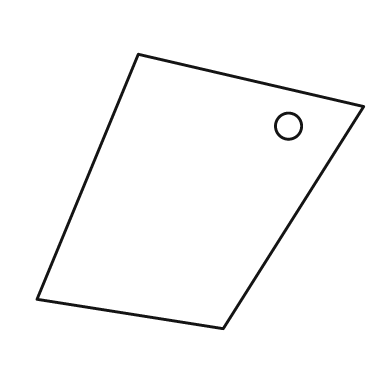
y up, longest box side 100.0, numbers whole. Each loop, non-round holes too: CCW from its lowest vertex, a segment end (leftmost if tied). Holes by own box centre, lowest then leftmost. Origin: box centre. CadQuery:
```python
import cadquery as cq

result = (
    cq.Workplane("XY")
    .moveTo(7.0, -42.0)
    .lineTo(50.0, 26.0)
    .lineTo(-19.0, 42.0)
    .lineTo(-50.0, -33.0)
    .close()
    .moveTo(27.0, 20.0)
    .circle(4.0)
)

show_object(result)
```